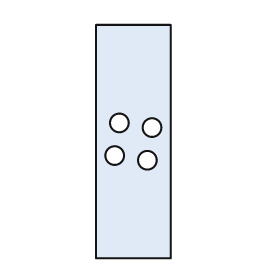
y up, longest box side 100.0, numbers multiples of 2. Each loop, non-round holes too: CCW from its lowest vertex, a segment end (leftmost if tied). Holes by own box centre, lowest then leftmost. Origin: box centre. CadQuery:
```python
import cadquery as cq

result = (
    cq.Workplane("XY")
    .moveTo(-16.0, -50.0)
    .lineTo(16.0, -50.0)
    .lineTo(16.0, 50.0)
    .lineTo(-16.0, 50.0)
    .close()
    .moveTo(6.0, -8.0)
    .circle(4.0)
    .moveTo(-8.0, -6.0)
    .circle(4.0)
    .moveTo(8.0, 6.0)
    .circle(4.0)
    .moveTo(-6.0, 8.0)
    .circle(4.0)
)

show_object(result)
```